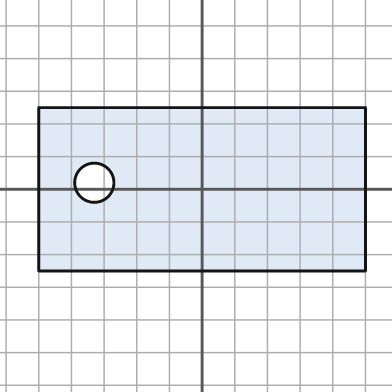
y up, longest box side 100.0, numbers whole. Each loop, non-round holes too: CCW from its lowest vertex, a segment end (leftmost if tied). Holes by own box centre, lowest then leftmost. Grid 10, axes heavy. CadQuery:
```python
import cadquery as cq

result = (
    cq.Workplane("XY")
    .moveTo(-50.0, -25.0)
    .lineTo(50.0, -25.0)
    .lineTo(50.0, 25.0)
    .lineTo(-50.0, 25.0)
    .close()
    .moveTo(-33.0, 2.0)
    .circle(6.0)
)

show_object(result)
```